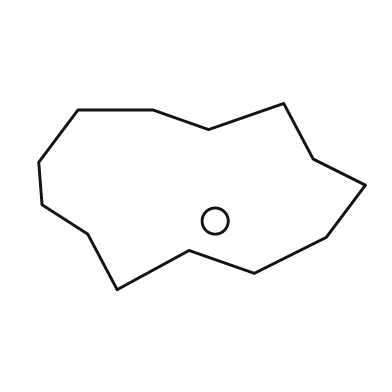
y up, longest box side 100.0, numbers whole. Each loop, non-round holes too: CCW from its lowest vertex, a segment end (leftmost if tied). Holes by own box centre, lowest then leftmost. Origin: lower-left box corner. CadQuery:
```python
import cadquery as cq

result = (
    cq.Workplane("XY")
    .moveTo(24.0, 0.0)
    .lineTo(46.0, 12.0)
    .lineTo(66.0, 5.0)
    .lineTo(88.0, 16.0)
    .lineTo(100.0, 32.0)
    .lineTo(84.0, 40.0)
    .lineTo(75.0, 57.0)
    .lineTo(52.0, 49.0)
    .lineTo(35.0, 55.0)
    .lineTo(12.0, 55.0)
    .lineTo(0.0, 39.0)
    .lineTo(1.0, 26.0)
    .lineTo(15.0, 17.0)
    .close()
    .moveTo(54.0, 21.0)
    .circle(4.0)
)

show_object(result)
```